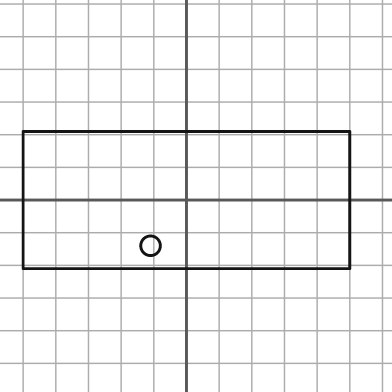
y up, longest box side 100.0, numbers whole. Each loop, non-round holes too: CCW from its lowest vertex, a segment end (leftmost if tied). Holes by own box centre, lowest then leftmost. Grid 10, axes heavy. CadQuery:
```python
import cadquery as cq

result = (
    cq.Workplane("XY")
    .moveTo(-50.0, -21.0)
    .lineTo(50.0, -21.0)
    .lineTo(50.0, 21.0)
    .lineTo(-50.0, 21.0)
    .close()
    .moveTo(-11.0, -14.0)
    .circle(3.0)
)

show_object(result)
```